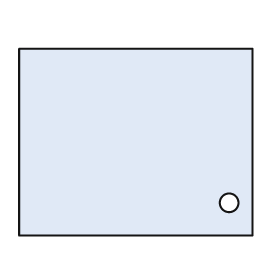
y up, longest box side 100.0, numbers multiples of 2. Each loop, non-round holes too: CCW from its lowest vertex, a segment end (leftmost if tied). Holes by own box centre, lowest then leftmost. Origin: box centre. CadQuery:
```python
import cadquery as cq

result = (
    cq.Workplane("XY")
    .moveTo(-50.0, -40.0)
    .lineTo(50.0, -40.0)
    .lineTo(50.0, 40.0)
    .lineTo(-50.0, 40.0)
    .close()
    .moveTo(40.0, -26.0)
    .circle(4.0)
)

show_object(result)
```